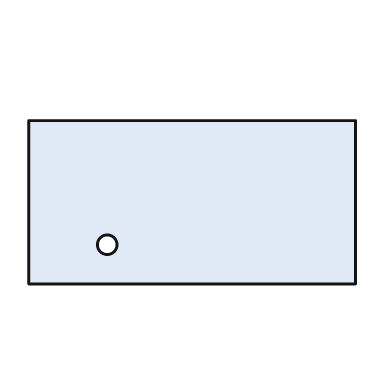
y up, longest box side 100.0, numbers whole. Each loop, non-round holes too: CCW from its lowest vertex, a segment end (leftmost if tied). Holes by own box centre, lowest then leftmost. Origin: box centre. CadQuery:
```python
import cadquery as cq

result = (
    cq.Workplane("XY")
    .moveTo(-50.0, -25.0)
    .lineTo(50.0, -25.0)
    .lineTo(50.0, 25.0)
    .lineTo(-50.0, 25.0)
    .close()
    .moveTo(-26.0, -13.0)
    .circle(3.0)
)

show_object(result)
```